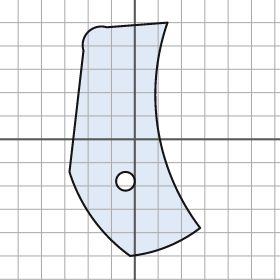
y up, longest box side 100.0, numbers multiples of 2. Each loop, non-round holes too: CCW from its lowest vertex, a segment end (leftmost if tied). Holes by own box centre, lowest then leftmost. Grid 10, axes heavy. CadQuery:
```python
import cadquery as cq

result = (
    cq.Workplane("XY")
    .moveTo(-2.0, -50.0)
    .threePointArc((14.0, -46.0), (28.0, -38.0))
    .threePointArc((10.0, 4.0), (14.0, 50.0))
    .lineTo(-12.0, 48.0)
    .threePointArc((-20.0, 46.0), (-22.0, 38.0))
    .lineTo(-28.0, -14.0)
    .threePointArc((-18.0, -34.0), (-2.0, -50.0))
    .close()
    .moveTo(-4.0, -18.0)
    .circle(4.0)
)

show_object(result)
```